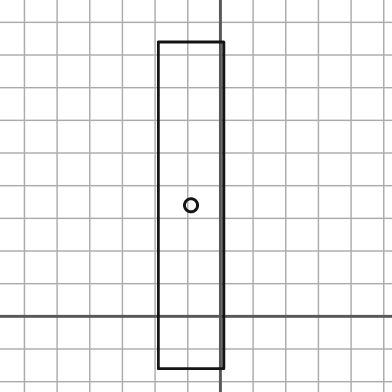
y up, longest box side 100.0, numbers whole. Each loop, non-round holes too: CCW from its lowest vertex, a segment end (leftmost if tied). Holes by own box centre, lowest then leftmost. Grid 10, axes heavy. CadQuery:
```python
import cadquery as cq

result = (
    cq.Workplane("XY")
    .moveTo(-19.0, -16.0)
    .lineTo(1.0, -16.0)
    .lineTo(1.0, 84.0)
    .lineTo(-19.0, 84.0)
    .close()
    .moveTo(-9.0, 34.0)
    .circle(2.0)
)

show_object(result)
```